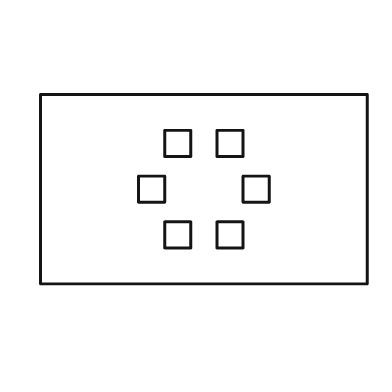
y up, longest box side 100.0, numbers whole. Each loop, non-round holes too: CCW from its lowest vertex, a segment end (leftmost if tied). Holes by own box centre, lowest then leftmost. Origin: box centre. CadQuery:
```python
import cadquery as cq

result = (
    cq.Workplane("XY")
    .moveTo(-50.0, -29.0)
    .lineTo(50.0, -29.0)
    .lineTo(50.0, 29.0)
    .lineTo(-50.0, 29.0)
    .close()
    .moveTo(-12.0, -18.0)
    .lineTo(-4.0, -18.0)
    .lineTo(-4.0, -10.0)
    .lineTo(-12.0, -10.0)
    .close()
    .moveTo(4.0, -18.0)
    .lineTo(12.0, -18.0)
    .lineTo(12.0, -10.0)
    .lineTo(4.0, -10.0)
    .close()
    .moveTo(-20.0, -4.0)
    .lineTo(-12.0, -4.0)
    .lineTo(-12.0, 4.0)
    .lineTo(-20.0, 4.0)
    .close()
    .moveTo(12.0, -4.0)
    .lineTo(20.0, -4.0)
    .lineTo(20.0, 4.0)
    .lineTo(12.0, 4.0)
    .close()
    .moveTo(-12.0, 10.0)
    .lineTo(-4.0, 10.0)
    .lineTo(-4.0, 18.0)
    .lineTo(-12.0, 18.0)
    .close()
    .moveTo(4.0, 10.0)
    .lineTo(12.0, 10.0)
    .lineTo(12.0, 18.0)
    .lineTo(4.0, 18.0)
    .close()
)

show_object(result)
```